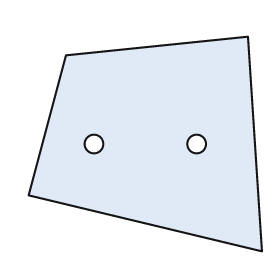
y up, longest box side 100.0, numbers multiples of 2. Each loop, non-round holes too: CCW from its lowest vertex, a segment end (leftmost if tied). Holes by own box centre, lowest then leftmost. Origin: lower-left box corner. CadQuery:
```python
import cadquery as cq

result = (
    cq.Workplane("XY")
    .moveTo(100.0, 0.0)
    .lineTo(94.0, 92.0)
    .lineTo(16.0, 84.0)
    .lineTo(0.0, 24.0)
    .close()
    .moveTo(28.0, 46.0)
    .circle(4.0)
    .moveTo(72.0, 46.0)
    .circle(4.0)
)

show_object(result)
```